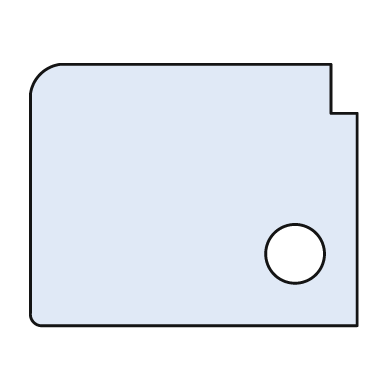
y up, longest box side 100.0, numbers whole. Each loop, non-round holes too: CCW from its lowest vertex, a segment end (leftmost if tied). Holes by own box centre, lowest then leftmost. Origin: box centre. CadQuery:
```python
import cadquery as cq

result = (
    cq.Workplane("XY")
    .moveTo(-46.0, -40.0)
    .lineTo(50.0, -40.0)
    .lineTo(50.0, 25.0)
    .lineTo(42.0, 25.0)
    .lineTo(42.0, 40.0)
    .lineTo(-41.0, 40.0)
    .threePointArc((-47.0, 37.0), (-50.0, 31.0))
    .lineTo(-50.0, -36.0)
    .threePointArc((-49.0, -39.0), (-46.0, -40.0))
    .close()
    .moveTo(31.0, -18.0)
    .circle(9.0)
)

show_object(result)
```